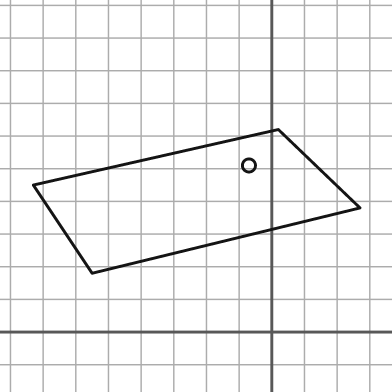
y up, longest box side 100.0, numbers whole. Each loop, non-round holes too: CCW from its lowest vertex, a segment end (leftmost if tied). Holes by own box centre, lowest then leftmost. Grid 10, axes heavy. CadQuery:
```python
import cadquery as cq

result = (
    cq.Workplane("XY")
    .moveTo(-55.0, 18.0)
    .lineTo(27.0, 38.0)
    .lineTo(2.0, 62.0)
    .lineTo(-73.0, 45.0)
    .close()
    .moveTo(-7.0, 51.0)
    .circle(2.0)
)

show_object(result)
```